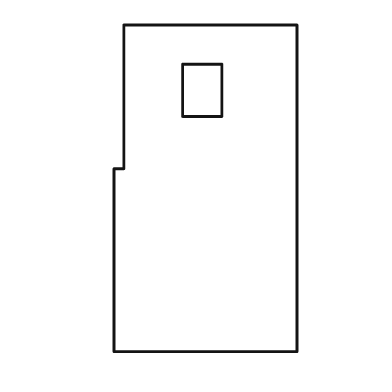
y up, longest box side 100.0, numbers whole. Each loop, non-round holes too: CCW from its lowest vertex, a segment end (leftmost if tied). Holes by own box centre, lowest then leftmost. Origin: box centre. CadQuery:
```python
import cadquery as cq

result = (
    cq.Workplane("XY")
    .moveTo(-28.0, -50.0)
    .lineTo(28.0, -50.0)
    .lineTo(28.0, 50.0)
    .lineTo(-25.0, 50.0)
    .lineTo(-25.0, 6.0)
    .lineTo(-28.0, 6.0)
    .close()
    .moveTo(-7.0, 22.0)
    .lineTo(5.0, 22.0)
    .lineTo(5.0, 38.0)
    .lineTo(-7.0, 38.0)
    .close()
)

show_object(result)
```